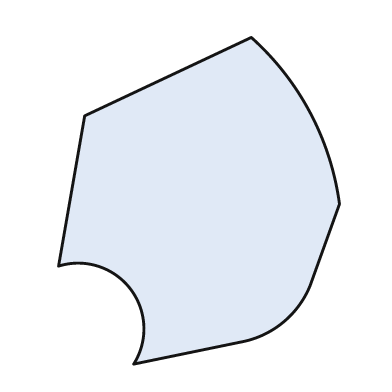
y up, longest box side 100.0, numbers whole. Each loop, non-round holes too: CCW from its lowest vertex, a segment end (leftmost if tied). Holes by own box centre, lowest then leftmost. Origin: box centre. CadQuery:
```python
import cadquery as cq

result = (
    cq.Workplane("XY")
    .moveTo(-20.0, -50.0)
    .lineTo(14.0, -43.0)
    .threePointArc((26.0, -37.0), (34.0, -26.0))
    .lineTo(43.0, -1.0)
    .threePointArc((34.0, 27.0), (16.0, 50.0))
    .lineTo(-35.0, 26.0)
    .lineTo(-43.0, -20.0)
    .threePointArc((-21.0, -27.0), (-20.0, -50.0))
    .close()
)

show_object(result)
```